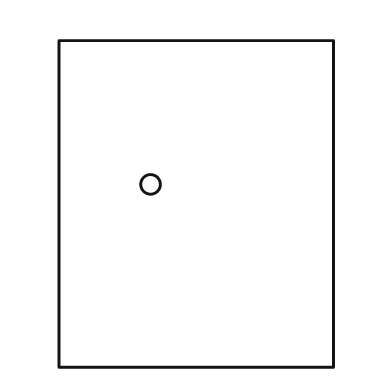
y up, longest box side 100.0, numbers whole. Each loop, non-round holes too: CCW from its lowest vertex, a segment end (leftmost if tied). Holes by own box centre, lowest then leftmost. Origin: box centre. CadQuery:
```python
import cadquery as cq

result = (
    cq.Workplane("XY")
    .moveTo(-42.0, -50.0)
    .lineTo(42.0, -50.0)
    .lineTo(42.0, 50.0)
    .lineTo(-42.0, 50.0)
    .close()
    .moveTo(-14.0, 6.0)
    .circle(3.0)
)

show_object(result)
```